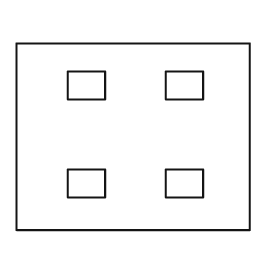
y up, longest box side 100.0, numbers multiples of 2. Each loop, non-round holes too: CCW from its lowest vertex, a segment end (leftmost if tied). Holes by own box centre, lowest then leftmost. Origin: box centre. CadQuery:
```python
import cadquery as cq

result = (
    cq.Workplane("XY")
    .moveTo(-50.0, -40.0)
    .lineTo(50.0, -40.0)
    .lineTo(50.0, 40.0)
    .lineTo(-50.0, 40.0)
    .close()
    .moveTo(-28.0, -26.0)
    .lineTo(-12.0, -26.0)
    .lineTo(-12.0, -14.0)
    .lineTo(-28.0, -14.0)
    .close()
    .moveTo(14.0, -26.0)
    .lineTo(30.0, -26.0)
    .lineTo(30.0, -14.0)
    .lineTo(14.0, -14.0)
    .close()
    .moveTo(-28.0, 16.0)
    .lineTo(-12.0, 16.0)
    .lineTo(-12.0, 28.0)
    .lineTo(-28.0, 28.0)
    .close()
    .moveTo(14.0, 16.0)
    .lineTo(30.0, 16.0)
    .lineTo(30.0, 28.0)
    .lineTo(14.0, 28.0)
    .close()
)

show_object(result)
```